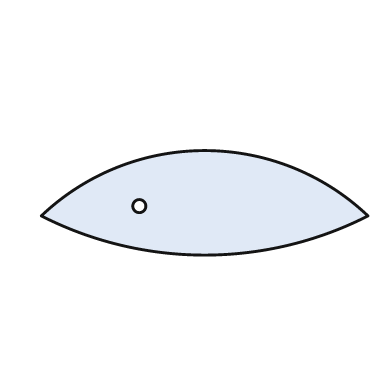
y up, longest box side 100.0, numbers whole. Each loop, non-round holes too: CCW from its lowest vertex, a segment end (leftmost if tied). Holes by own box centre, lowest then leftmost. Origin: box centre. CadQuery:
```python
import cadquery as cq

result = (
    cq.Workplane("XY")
    .moveTo(-50.0, -4.0)
    .threePointArc((0.0, -16.0), (50.0, -4.0))
    .threePointArc((0.0, 16.0), (-50.0, -4.0))
    .close()
    .moveTo(-20.0, -1.0)
    .circle(2.0)
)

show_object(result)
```